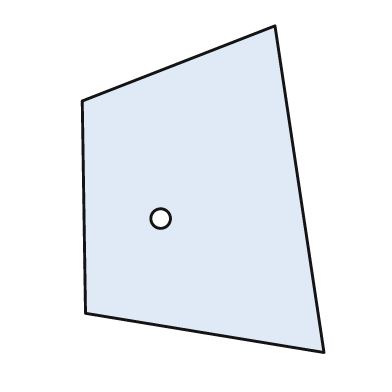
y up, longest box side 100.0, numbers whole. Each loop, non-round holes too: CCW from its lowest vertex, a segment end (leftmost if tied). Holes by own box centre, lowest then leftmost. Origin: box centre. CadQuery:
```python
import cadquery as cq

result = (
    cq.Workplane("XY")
    .moveTo(37.0, -50.0)
    .lineTo(22.0, 50.0)
    .lineTo(-37.0, 27.0)
    .lineTo(-36.0, -38.0)
    .close()
    .moveTo(-13.0, -9.0)
    .circle(3.0)
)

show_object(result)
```